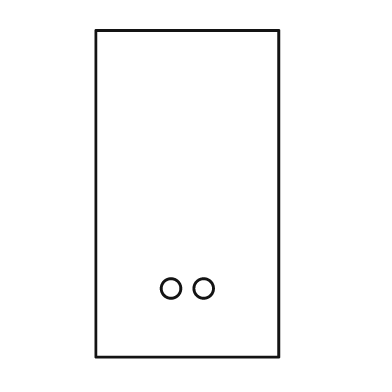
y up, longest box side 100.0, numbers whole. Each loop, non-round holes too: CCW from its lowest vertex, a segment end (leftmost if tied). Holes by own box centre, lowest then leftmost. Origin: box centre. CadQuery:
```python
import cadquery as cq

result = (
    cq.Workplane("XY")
    .moveTo(-28.0, -50.0)
    .lineTo(28.0, -50.0)
    .lineTo(28.0, 50.0)
    .lineTo(-28.0, 50.0)
    .close()
    .moveTo(-5.0, -29.0)
    .circle(3.0)
    .moveTo(5.0, -29.0)
    .circle(3.0)
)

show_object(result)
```